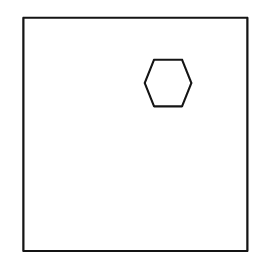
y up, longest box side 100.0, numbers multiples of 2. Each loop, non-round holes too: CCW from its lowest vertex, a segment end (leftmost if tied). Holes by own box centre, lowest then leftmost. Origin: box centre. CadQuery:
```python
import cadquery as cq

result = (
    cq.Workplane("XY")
    .moveTo(-48.0, -50.0)
    .lineTo(48.0, -50.0)
    .lineTo(48.0, 50.0)
    .lineTo(-48.0, 50.0)
    .close()
    .moveTo(8.0, 12.0)
    .lineTo(20.0, 12.0)
    .lineTo(24.0, 22.0)
    .lineTo(20.0, 32.0)
    .lineTo(8.0, 32.0)
    .lineTo(4.0, 22.0)
    .close()
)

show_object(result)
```